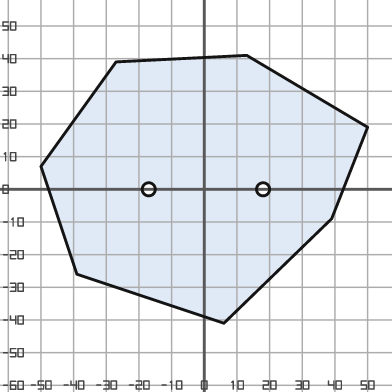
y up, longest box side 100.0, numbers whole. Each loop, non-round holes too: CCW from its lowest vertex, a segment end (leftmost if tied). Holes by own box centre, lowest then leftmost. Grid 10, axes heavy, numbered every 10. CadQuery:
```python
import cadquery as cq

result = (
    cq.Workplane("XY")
    .moveTo(6.0, -41.0)
    .lineTo(39.0, -9.0)
    .lineTo(50.0, 19.0)
    .lineTo(13.0, 41.0)
    .lineTo(-27.0, 39.0)
    .lineTo(-50.0, 7.0)
    .lineTo(-39.0, -26.0)
    .close()
    .moveTo(-17.0, 0.0)
    .circle(2.0)
    .moveTo(18.0, 0.0)
    .circle(2.0)
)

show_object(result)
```